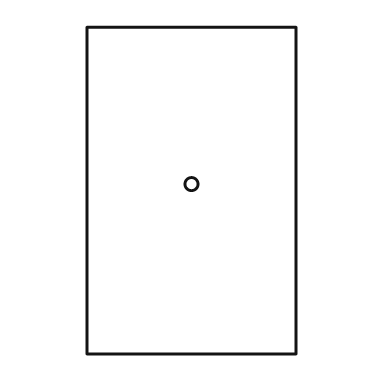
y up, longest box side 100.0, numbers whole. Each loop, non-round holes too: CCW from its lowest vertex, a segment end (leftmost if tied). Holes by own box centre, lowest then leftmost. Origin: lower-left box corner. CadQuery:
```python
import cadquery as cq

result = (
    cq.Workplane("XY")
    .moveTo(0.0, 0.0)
    .lineTo(64.0, 0.0)
    .lineTo(64.0, 100.0)
    .lineTo(0.0, 100.0)
    .close()
    .moveTo(32.0, 52.0)
    .circle(2.0)
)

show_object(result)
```